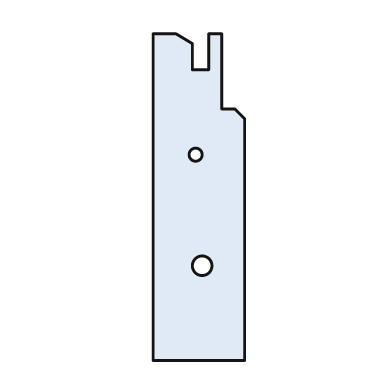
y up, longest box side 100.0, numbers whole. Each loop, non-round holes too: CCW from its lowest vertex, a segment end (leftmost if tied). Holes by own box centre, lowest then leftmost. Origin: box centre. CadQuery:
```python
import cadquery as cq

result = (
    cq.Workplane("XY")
    .moveTo(-14.0, -50.0)
    .lineTo(14.0, -50.0)
    .lineTo(14.0, 24.0)
    .lineTo(11.0, 27.0)
    .lineTo(7.0, 27.0)
    .lineTo(7.0, 50.0)
    .lineTo(3.0, 50.0)
    .lineTo(3.0, 39.0)
    .lineTo(-2.0, 39.0)
    .lineTo(-2.0, 47.0)
    .lineTo(-7.0, 50.0)
    .lineTo(-14.0, 50.0)
    .close()
    .moveTo(1.0, -21.0)
    .circle(3.0)
    .moveTo(-1.0, 13.0)
    .circle(2.0)
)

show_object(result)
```